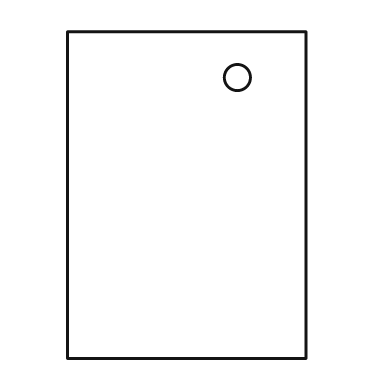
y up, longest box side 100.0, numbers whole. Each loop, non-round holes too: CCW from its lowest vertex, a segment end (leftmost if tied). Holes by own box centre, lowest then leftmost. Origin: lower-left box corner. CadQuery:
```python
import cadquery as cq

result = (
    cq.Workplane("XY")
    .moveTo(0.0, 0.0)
    .lineTo(73.0, 0.0)
    .lineTo(73.0, 100.0)
    .lineTo(0.0, 100.0)
    .close()
    .moveTo(52.0, 86.0)
    .circle(4.0)
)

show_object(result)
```